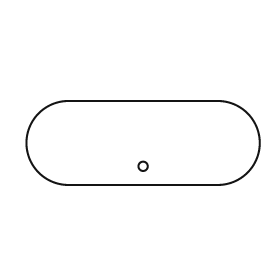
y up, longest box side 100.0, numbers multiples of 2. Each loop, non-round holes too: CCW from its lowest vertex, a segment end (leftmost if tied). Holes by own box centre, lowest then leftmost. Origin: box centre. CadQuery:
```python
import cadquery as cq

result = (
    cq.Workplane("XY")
    .moveTo(-32.0, -18.0)
    .lineTo(32.0, -18.0)
    .threePointArc((50.0, 0.0), (32.0, 18.0))
    .lineTo(-32.0, 18.0)
    .threePointArc((-50.0, 0.0), (-32.0, -18.0))
    .close()
    .moveTo(0.0, -10.0)
    .circle(2.0)
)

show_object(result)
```